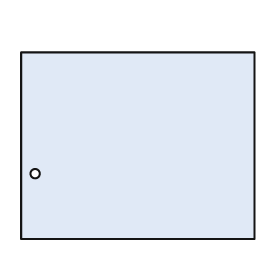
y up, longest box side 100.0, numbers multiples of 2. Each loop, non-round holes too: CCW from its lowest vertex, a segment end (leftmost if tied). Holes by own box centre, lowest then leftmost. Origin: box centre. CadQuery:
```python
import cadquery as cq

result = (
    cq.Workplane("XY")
    .moveTo(-50.0, -40.0)
    .lineTo(50.0, -40.0)
    .lineTo(50.0, 40.0)
    .lineTo(-50.0, 40.0)
    .close()
    .moveTo(-44.0, -12.0)
    .circle(2.0)
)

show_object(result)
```